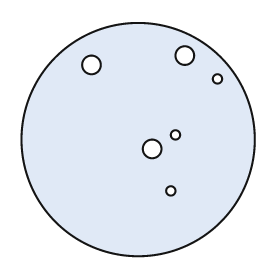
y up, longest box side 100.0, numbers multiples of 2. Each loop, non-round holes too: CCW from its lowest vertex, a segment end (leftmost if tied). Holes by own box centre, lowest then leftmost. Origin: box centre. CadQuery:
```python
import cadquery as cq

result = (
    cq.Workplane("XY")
    .moveTo(0.0, 0.0)
    .circle(50.0)
    .moveTo(14.0, -22.0)
    .circle(2.0)
    .moveTo(6.0, -4.0)
    .circle(4.0)
    .moveTo(16.0, 2.0)
    .circle(2.0)
    .moveTo(34.0, 26.0)
    .circle(2.0)
    .moveTo(-20.0, 32.0)
    .circle(4.0)
    .moveTo(20.0, 36.0)
    .circle(4.0)
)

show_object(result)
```